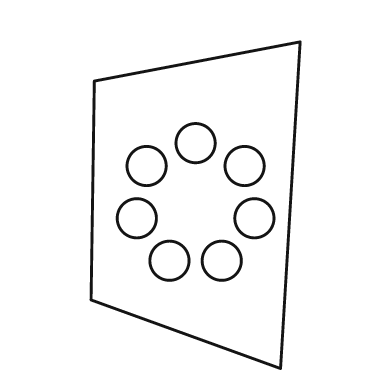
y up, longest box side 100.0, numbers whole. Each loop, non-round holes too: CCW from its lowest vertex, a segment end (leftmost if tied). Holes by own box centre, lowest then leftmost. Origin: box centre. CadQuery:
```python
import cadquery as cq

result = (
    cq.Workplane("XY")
    .moveTo(26.0, -50.0)
    .lineTo(32.0, 50.0)
    .lineTo(-31.0, 38.0)
    .lineTo(-32.0, -29.0)
    .close()
    .moveTo(-8.0, -17.0)
    .circle(6.0)
    .moveTo(8.0, -17.0)
    .circle(6.0)
    .moveTo(-18.0, -4.0)
    .circle(6.0)
    .moveTo(18.0, -4.0)
    .circle(6.0)
    .moveTo(-15.0, 12.0)
    .circle(6.0)
    .moveTo(15.0, 12.0)
    .circle(6.0)
    .moveTo(0.0, 19.0)
    .circle(6.0)
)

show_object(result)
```